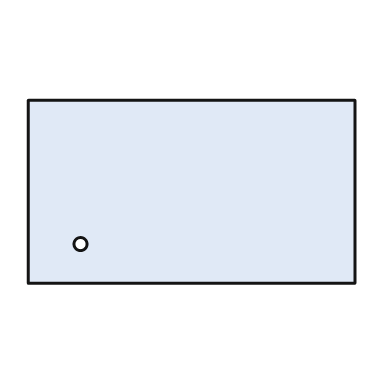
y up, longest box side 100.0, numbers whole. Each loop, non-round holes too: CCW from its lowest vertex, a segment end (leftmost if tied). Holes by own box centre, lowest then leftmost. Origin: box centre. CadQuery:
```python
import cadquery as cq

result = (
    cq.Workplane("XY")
    .moveTo(-50.0, -28.0)
    .lineTo(50.0, -28.0)
    .lineTo(50.0, 28.0)
    .lineTo(-50.0, 28.0)
    .close()
    .moveTo(-34.0, -16.0)
    .circle(2.0)
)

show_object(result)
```